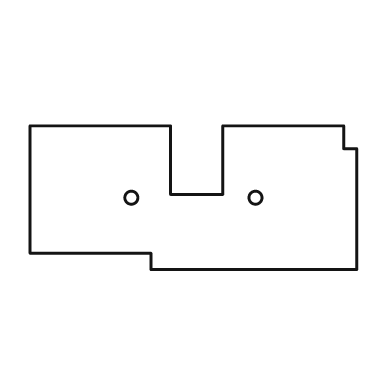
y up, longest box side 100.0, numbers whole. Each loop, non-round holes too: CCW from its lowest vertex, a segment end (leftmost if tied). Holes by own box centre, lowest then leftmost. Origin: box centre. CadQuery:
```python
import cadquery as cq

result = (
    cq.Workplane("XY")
    .moveTo(-13.0, -22.0)
    .lineTo(50.0, -22.0)
    .lineTo(50.0, 15.0)
    .lineTo(46.0, 15.0)
    .lineTo(46.0, 22.0)
    .lineTo(9.0, 22.0)
    .lineTo(9.0, 1.0)
    .lineTo(-7.0, 1.0)
    .lineTo(-7.0, 22.0)
    .lineTo(-50.0, 22.0)
    .lineTo(-50.0, -17.0)
    .lineTo(-13.0, -17.0)
    .close()
    .moveTo(-19.0, 0.0)
    .circle(2.0)
    .moveTo(19.0, 0.0)
    .circle(2.0)
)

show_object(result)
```